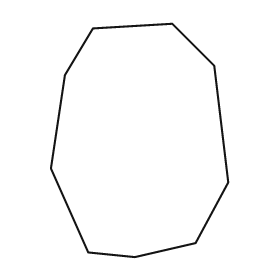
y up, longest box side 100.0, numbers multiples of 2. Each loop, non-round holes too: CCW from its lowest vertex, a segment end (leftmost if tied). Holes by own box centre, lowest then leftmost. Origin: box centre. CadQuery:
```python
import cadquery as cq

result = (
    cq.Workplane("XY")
    .moveTo(-2.0, -50.0)
    .lineTo(24.0, -44.0)
    .lineTo(38.0, -18.0)
    .lineTo(32.0, 32.0)
    .lineTo(14.0, 50.0)
    .lineTo(-20.0, 48.0)
    .lineTo(-32.0, 28.0)
    .lineTo(-38.0, -12.0)
    .lineTo(-22.0, -48.0)
    .close()
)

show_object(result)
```